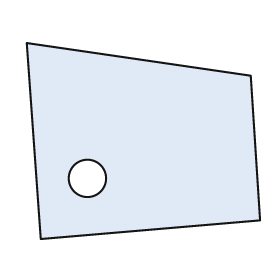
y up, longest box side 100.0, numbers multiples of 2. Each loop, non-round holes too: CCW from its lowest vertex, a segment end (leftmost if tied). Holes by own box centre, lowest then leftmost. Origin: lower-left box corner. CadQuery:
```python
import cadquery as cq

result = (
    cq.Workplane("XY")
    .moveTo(6.0, 0.0)
    .lineTo(100.0, 8.0)
    .lineTo(96.0, 70.0)
    .lineTo(0.0, 84.0)
    .close()
    .moveTo(26.0, 26.0)
    .circle(8.0)
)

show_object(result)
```